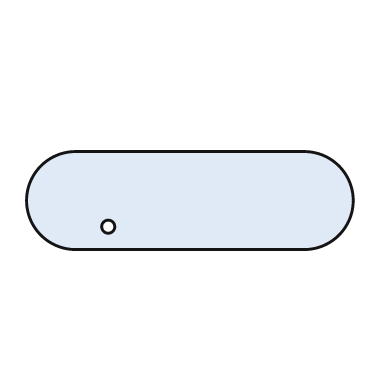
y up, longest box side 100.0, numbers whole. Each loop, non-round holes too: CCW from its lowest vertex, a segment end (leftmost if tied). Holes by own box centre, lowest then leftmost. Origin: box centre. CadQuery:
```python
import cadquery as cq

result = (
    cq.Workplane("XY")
    .moveTo(-35.0, -15.0)
    .lineTo(35.0, -15.0)
    .threePointArc((50.0, 0.0), (35.0, 15.0))
    .lineTo(-35.0, 15.0)
    .threePointArc((-50.0, 0.0), (-35.0, -15.0))
    .close()
    .moveTo(-25.0, -8.0)
    .circle(2.0)
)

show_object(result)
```